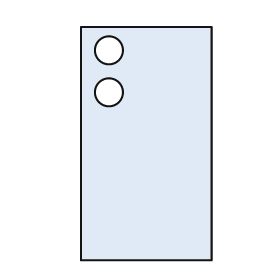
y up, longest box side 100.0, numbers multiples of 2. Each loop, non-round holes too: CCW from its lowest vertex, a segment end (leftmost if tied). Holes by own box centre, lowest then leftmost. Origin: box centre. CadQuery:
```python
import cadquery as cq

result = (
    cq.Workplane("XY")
    .moveTo(-28.0, -50.0)
    .lineTo(28.0, -50.0)
    .lineTo(28.0, 50.0)
    .lineTo(-28.0, 50.0)
    .close()
    .moveTo(-16.0, 22.0)
    .circle(6.0)
    .moveTo(-16.0, 40.0)
    .circle(6.0)
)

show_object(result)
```